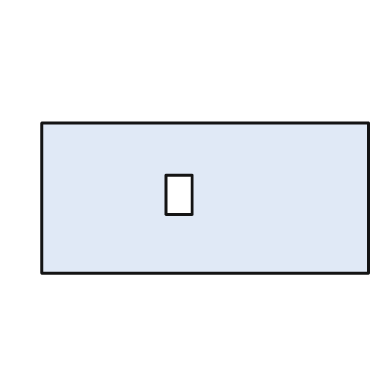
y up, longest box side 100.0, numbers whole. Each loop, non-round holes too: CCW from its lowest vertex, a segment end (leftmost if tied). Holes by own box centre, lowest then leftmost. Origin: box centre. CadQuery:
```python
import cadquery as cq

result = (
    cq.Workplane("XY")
    .moveTo(-50.0, -23.0)
    .lineTo(50.0, -23.0)
    .lineTo(50.0, 23.0)
    .lineTo(-50.0, 23.0)
    .close()
    .moveTo(-12.0, -5.0)
    .lineTo(-4.0, -5.0)
    .lineTo(-4.0, 7.0)
    .lineTo(-12.0, 7.0)
    .close()
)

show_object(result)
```